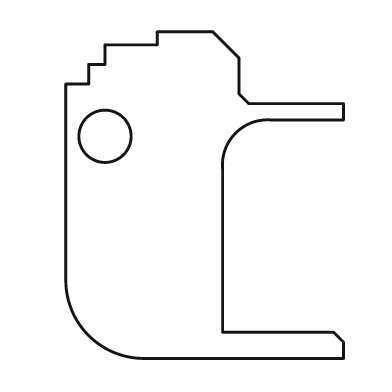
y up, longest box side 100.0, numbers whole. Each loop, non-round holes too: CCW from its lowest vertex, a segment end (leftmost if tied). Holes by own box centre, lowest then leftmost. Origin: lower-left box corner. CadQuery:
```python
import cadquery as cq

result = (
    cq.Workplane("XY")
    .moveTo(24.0, 0.0)
    .lineTo(85.0, 0.0)
    .lineTo(85.0, 5.0)
    .lineTo(82.0, 8.0)
    .lineTo(48.0, 8.0)
    .lineTo(48.0, 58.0)
    .threePointArc((52.0, 69.0), (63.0, 73.0))
    .lineTo(85.0, 73.0)
    .lineTo(85.0, 78.0)
    .lineTo(56.0, 78.0)
    .lineTo(53.0, 81.0)
    .lineTo(53.0, 92.0)
    .lineTo(45.0, 100.0)
    .lineTo(28.0, 100.0)
    .lineTo(28.0, 96.0)
    .lineTo(12.0, 96.0)
    .lineTo(12.0, 90.0)
    .lineTo(7.0, 90.0)
    .lineTo(7.0, 84.0)
    .lineTo(0.0, 84.0)
    .lineTo(0.0, 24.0)
    .threePointArc((7.0, 7.0), (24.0, 0.0))
    .close()
    .moveTo(12.0, 68.0)
    .circle(8.0)
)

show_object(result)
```